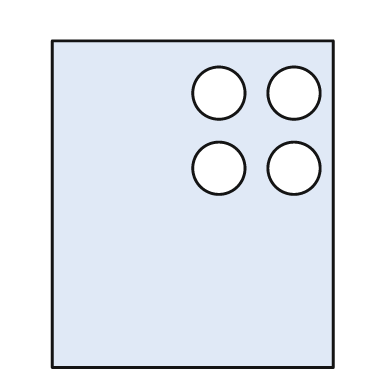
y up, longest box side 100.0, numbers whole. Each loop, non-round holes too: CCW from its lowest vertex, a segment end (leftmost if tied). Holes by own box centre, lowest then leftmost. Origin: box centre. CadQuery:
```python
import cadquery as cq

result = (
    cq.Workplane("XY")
    .moveTo(-43.0, -50.0)
    .lineTo(43.0, -50.0)
    .lineTo(43.0, 50.0)
    .lineTo(-43.0, 50.0)
    .close()
    .moveTo(8.0, 11.0)
    .circle(8.0)
    .moveTo(31.0, 11.0)
    .circle(8.0)
    .moveTo(8.0, 34.0)
    .circle(8.0)
    .moveTo(31.0, 34.0)
    .circle(8.0)
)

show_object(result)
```